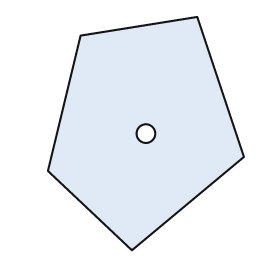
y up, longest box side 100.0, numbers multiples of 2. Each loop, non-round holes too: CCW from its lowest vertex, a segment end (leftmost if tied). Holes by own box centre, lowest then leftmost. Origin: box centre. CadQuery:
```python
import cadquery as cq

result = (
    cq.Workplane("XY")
    .moveTo(-6.0, -50.0)
    .lineTo(42.0, -10.0)
    .lineTo(22.0, 50.0)
    .lineTo(-28.0, 42.0)
    .lineTo(-42.0, -16.0)
    .close()
    .moveTo(0.0, 0.0)
    .circle(4.0)
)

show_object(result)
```